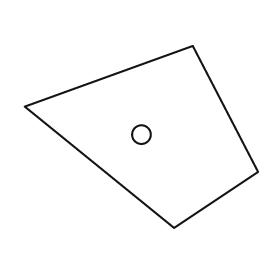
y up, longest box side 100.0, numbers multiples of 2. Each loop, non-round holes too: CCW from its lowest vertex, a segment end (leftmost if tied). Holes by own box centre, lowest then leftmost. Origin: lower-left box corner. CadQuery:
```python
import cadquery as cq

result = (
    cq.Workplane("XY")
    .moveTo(64.0, 0.0)
    .lineTo(100.0, 24.0)
    .lineTo(72.0, 78.0)
    .lineTo(0.0, 52.0)
    .close()
    .moveTo(50.0, 40.0)
    .circle(4.0)
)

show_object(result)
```